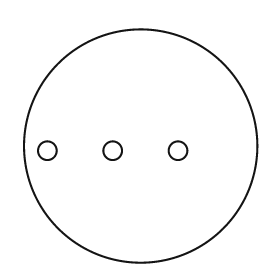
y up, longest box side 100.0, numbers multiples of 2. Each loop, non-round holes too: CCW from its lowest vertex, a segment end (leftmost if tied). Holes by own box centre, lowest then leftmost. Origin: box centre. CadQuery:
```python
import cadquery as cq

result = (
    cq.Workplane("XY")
    .moveTo(0.0, 0.0)
    .circle(50.0)
    .moveTo(-40.0, -2.0)
    .circle(4.0)
    .moveTo(-12.0, -2.0)
    .circle(4.0)
    .moveTo(16.0, -2.0)
    .circle(4.0)
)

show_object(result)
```